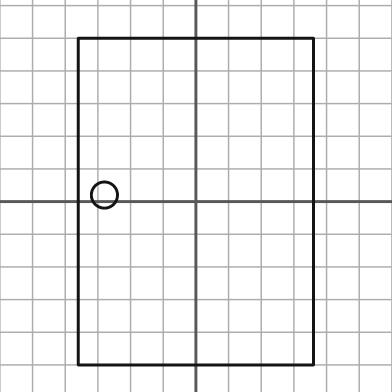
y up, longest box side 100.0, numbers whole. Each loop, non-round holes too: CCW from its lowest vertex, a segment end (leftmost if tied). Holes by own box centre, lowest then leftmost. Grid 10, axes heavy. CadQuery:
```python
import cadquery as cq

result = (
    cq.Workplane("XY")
    .moveTo(-36.0, -50.0)
    .lineTo(36.0, -50.0)
    .lineTo(36.0, 50.0)
    .lineTo(-36.0, 50.0)
    .close()
    .moveTo(-28.0, 2.0)
    .circle(4.0)
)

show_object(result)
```